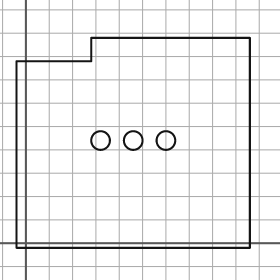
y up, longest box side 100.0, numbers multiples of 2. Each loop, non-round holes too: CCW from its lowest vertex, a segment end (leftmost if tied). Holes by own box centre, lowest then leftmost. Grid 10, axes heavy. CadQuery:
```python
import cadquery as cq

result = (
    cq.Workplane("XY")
    .moveTo(-4.0, -2.0)
    .lineTo(96.0, -2.0)
    .lineTo(96.0, 88.0)
    .lineTo(28.0, 88.0)
    .lineTo(28.0, 78.0)
    .lineTo(-4.0, 78.0)
    .close()
    .moveTo(32.0, 44.0)
    .circle(4.0)
    .moveTo(46.0, 44.0)
    .circle(4.0)
    .moveTo(60.0, 44.0)
    .circle(4.0)
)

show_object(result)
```